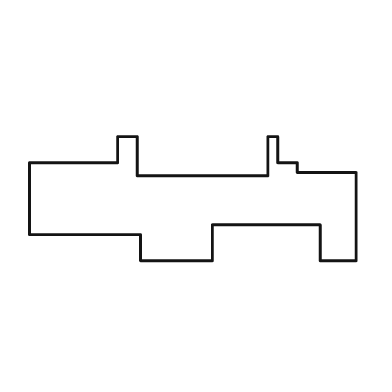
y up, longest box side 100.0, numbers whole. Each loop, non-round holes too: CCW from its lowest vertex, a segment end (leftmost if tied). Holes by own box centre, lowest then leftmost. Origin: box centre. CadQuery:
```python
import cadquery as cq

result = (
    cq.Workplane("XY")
    .moveTo(-16.0, -19.0)
    .lineTo(6.0, -19.0)
    .lineTo(6.0, -8.0)
    .lineTo(39.0, -8.0)
    .lineTo(39.0, -19.0)
    .lineTo(50.0, -19.0)
    .lineTo(50.0, 8.0)
    .lineTo(32.0, 8.0)
    .lineTo(32.0, 11.0)
    .lineTo(26.0, 11.0)
    .lineTo(26.0, 19.0)
    .lineTo(23.0, 19.0)
    .lineTo(23.0, 7.0)
    .lineTo(-17.0, 7.0)
    .lineTo(-17.0, 19.0)
    .lineTo(-23.0, 19.0)
    .lineTo(-23.0, 11.0)
    .lineTo(-50.0, 11.0)
    .lineTo(-50.0, -11.0)
    .lineTo(-16.0, -11.0)
    .close()
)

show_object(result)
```